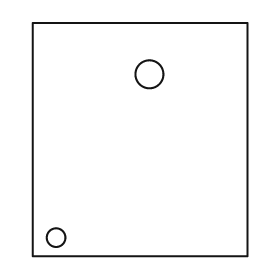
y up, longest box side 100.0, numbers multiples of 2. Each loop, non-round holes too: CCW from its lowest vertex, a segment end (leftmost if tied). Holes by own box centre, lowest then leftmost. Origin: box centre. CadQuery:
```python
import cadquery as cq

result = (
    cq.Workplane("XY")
    .moveTo(-46.0, -50.0)
    .lineTo(46.0, -50.0)
    .lineTo(46.0, 50.0)
    .lineTo(-46.0, 50.0)
    .close()
    .moveTo(-36.0, -42.0)
    .circle(4.0)
    .moveTo(4.0, 28.0)
    .circle(6.0)
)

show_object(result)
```